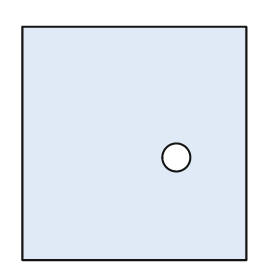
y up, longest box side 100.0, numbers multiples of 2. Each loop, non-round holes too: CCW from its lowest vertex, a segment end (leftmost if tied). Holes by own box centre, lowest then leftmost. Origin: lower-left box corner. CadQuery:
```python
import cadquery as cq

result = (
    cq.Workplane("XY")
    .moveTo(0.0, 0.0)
    .lineTo(96.0, 0.0)
    .lineTo(96.0, 100.0)
    .lineTo(0.0, 100.0)
    .close()
    .moveTo(66.0, 44.0)
    .circle(6.0)
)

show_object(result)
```